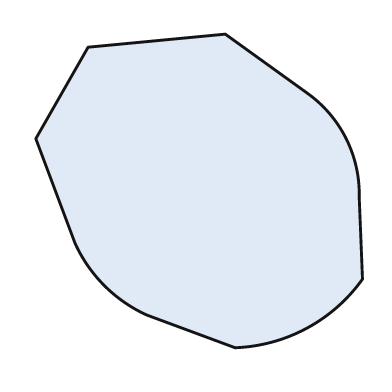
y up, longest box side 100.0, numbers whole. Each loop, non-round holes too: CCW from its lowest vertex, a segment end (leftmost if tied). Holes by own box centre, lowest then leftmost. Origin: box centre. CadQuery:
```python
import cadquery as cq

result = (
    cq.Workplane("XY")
    .moveTo(11.0, -48.0)
    .threePointArc((33.0, -42.0), (50.0, -27.0))
    .lineTo(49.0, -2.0)
    .threePointArc((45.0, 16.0), (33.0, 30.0))
    .lineTo(8.0, 48.0)
    .lineTo(-34.0, 44.0)
    .lineTo(-50.0, 16.0)
    .lineTo(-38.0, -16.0)
    .threePointArc((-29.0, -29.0), (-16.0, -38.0))
    .close()
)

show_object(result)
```